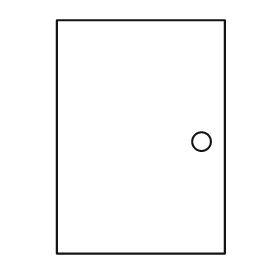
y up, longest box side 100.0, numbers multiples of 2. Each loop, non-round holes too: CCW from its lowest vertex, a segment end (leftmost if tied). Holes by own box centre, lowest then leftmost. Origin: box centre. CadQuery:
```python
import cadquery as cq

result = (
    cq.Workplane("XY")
    .moveTo(-36.0, -50.0)
    .lineTo(36.0, -50.0)
    .lineTo(36.0, 50.0)
    .lineTo(-36.0, 50.0)
    .close()
    .moveTo(26.0, -2.0)
    .circle(4.0)
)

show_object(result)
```